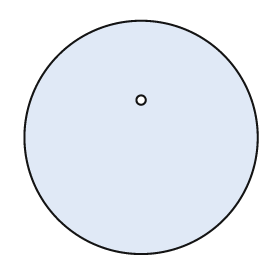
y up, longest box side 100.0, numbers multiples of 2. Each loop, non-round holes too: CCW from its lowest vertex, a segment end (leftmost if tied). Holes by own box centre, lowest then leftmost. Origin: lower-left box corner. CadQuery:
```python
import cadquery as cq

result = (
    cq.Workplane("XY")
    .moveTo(50.0, 50.0)
    .circle(50.0)
    .moveTo(50.0, 66.0)
    .circle(2.0)
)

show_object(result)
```